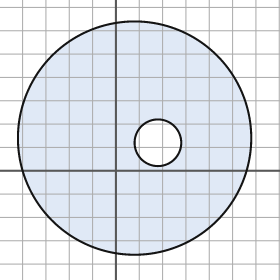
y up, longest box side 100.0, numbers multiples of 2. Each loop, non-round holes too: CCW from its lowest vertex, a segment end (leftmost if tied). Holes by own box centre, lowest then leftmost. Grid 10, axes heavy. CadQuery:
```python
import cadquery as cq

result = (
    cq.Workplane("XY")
    .moveTo(8.0, 14.0)
    .circle(50.0)
    .moveTo(18.0, 12.0)
    .circle(10.0)
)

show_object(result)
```